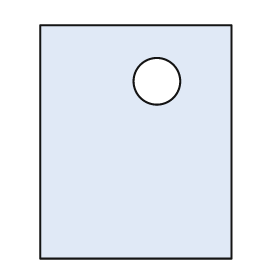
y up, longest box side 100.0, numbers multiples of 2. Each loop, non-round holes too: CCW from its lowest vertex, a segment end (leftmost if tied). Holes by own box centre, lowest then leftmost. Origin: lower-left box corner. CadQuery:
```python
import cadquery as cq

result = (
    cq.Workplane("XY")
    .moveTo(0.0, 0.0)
    .lineTo(82.0, 0.0)
    .lineTo(82.0, 100.0)
    .lineTo(0.0, 100.0)
    .close()
    .moveTo(50.0, 76.0)
    .circle(10.0)
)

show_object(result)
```